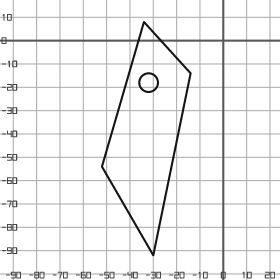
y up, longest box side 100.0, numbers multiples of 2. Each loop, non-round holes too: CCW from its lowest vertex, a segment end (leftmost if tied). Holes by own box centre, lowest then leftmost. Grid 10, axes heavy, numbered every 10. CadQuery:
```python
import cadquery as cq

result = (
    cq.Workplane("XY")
    .moveTo(-30.0, -92.0)
    .lineTo(-14.0, -14.0)
    .lineTo(-34.0, 8.0)
    .lineTo(-52.0, -54.0)
    .close()
    .moveTo(-32.0, -18.0)
    .circle(4.0)
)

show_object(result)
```